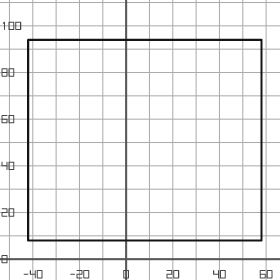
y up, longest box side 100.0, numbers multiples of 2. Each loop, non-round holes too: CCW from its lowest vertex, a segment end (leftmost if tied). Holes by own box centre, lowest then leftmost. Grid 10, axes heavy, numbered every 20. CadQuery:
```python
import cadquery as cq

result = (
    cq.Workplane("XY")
    .moveTo(-42.0, 8.0)
    .lineTo(58.0, 8.0)
    .lineTo(58.0, 94.0)
    .lineTo(-42.0, 94.0)
    .close()
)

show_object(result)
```